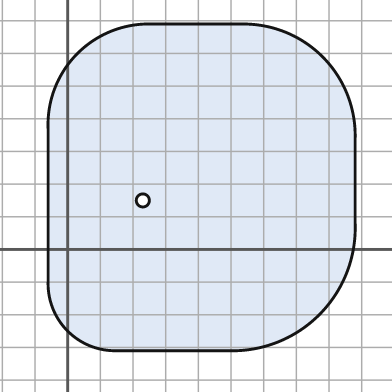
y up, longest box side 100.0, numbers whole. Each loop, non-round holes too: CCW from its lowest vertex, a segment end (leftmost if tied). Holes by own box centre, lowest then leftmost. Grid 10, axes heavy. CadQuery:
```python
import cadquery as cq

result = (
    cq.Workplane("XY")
    .moveTo(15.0, -31.0)
    .lineTo(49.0, -31.0)
    .threePointArc((77.0, -20.0), (88.0, 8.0))
    .lineTo(88.0, 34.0)
    .threePointArc((78.0, 59.0), (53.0, 69.0))
    .lineTo(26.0, 69.0)
    .threePointArc((3.0, 60.0), (-6.0, 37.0))
    .lineTo(-6.0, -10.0)
    .threePointArc((0.0, -25.0), (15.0, -31.0))
    .close()
    .moveTo(23.0, 15.0)
    .circle(2.0)
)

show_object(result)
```